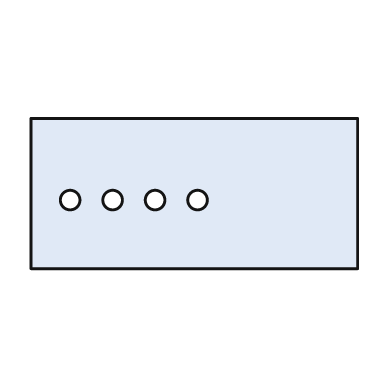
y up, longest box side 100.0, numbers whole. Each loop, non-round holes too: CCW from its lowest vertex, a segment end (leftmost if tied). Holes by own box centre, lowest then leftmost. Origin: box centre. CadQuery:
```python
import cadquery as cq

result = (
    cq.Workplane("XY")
    .moveTo(-50.0, -23.0)
    .lineTo(50.0, -23.0)
    .lineTo(50.0, 23.0)
    .lineTo(-50.0, 23.0)
    .close()
    .moveTo(-38.0, -2.0)
    .circle(3.0)
    .moveTo(-25.0, -2.0)
    .circle(3.0)
    .moveTo(-12.0, -2.0)
    .circle(3.0)
    .moveTo(1.0, -2.0)
    .circle(3.0)
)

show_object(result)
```